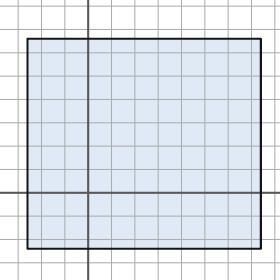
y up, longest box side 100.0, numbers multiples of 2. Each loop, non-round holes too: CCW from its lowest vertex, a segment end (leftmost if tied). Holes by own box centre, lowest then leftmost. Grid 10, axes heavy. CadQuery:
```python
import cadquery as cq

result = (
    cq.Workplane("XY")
    .moveTo(-26.0, -24.0)
    .lineTo(74.0, -24.0)
    .lineTo(74.0, 66.0)
    .lineTo(-26.0, 66.0)
    .close()
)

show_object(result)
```